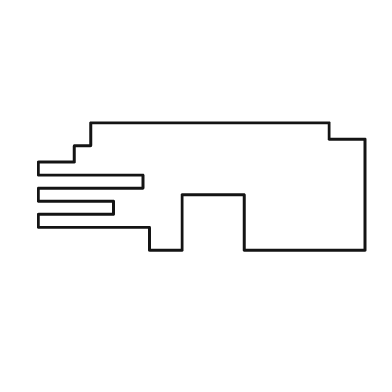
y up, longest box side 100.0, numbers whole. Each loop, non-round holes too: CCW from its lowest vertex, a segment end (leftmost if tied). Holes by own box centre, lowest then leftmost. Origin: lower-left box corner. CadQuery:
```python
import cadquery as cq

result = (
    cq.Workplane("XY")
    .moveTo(34.0, 0.0)
    .lineTo(44.0, 0.0)
    .lineTo(44.0, 17.0)
    .lineTo(63.0, 17.0)
    .lineTo(63.0, 0.0)
    .lineTo(100.0, 0.0)
    .lineTo(100.0, 34.0)
    .lineTo(89.0, 34.0)
    .lineTo(89.0, 39.0)
    .lineTo(16.0, 39.0)
    .lineTo(16.0, 32.0)
    .lineTo(11.0, 32.0)
    .lineTo(11.0, 27.0)
    .lineTo(0.0, 27.0)
    .lineTo(0.0, 23.0)
    .lineTo(32.0, 23.0)
    .lineTo(32.0, 19.0)
    .lineTo(0.0, 19.0)
    .lineTo(0.0, 15.0)
    .lineTo(23.0, 15.0)
    .lineTo(23.0, 11.0)
    .lineTo(0.0, 11.0)
    .lineTo(0.0, 7.0)
    .lineTo(34.0, 7.0)
    .close()
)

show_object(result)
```